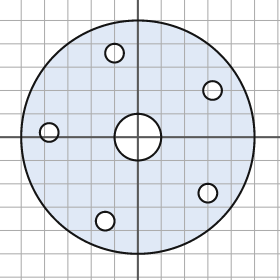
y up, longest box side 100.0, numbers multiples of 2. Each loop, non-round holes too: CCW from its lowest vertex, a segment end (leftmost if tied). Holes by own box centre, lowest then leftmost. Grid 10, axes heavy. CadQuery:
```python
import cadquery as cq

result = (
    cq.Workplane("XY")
    .moveTo(0.0, 0.0)
    .circle(50.0)
    .moveTo(-14.0, -36.0)
    .circle(4.0)
    .moveTo(30.0, -24.0)
    .circle(4.0)
    .moveTo(0.0, 0.0)
    .circle(10.0)
    .moveTo(-38.0, 2.0)
    .circle(4.0)
    .moveTo(32.0, 20.0)
    .circle(4.0)
    .moveTo(-10.0, 36.0)
    .circle(4.0)
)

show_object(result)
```